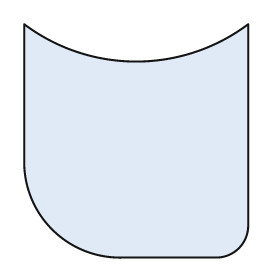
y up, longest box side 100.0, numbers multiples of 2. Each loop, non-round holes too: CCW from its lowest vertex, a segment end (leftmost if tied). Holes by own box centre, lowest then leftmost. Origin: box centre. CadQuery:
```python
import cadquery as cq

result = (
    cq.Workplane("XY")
    .moveTo(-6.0, -50.0)
    .lineTo(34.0, -50.0)
    .threePointArc((44.0, -46.0), (48.0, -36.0))
    .lineTo(48.0, 50.0)
    .threePointArc((0.0, 34.0), (-48.0, 50.0))
    .lineTo(-48.0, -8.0)
    .threePointArc((-36.0, -38.0), (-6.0, -50.0))
    .close()
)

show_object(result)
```